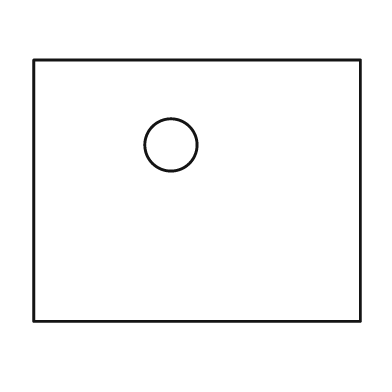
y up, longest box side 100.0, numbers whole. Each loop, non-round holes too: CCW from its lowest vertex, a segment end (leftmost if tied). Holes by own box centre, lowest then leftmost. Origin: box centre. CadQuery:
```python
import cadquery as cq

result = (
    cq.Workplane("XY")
    .moveTo(-50.0, -40.0)
    .lineTo(50.0, -40.0)
    .lineTo(50.0, 40.0)
    .lineTo(-50.0, 40.0)
    .close()
    .moveTo(-8.0, 14.0)
    .circle(8.0)
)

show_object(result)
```